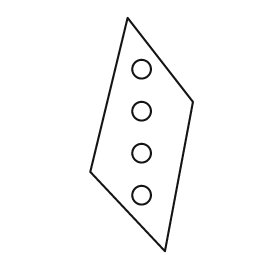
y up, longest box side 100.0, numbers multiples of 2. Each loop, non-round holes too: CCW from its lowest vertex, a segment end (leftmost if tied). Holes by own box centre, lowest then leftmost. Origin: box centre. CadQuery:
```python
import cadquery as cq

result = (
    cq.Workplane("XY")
    .moveTo(10.0, -50.0)
    .lineTo(22.0, 14.0)
    .lineTo(-6.0, 50.0)
    .lineTo(-22.0, -16.0)
    .close()
    .moveTo(0.0, -26.0)
    .circle(4.0)
    .moveTo(0.0, -8.0)
    .circle(4.0)
    .moveTo(0.0, 10.0)
    .circle(4.0)
    .moveTo(0.0, 28.0)
    .circle(4.0)
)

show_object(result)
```